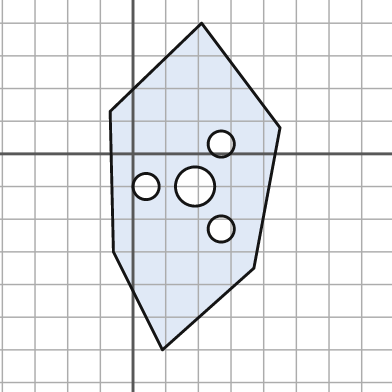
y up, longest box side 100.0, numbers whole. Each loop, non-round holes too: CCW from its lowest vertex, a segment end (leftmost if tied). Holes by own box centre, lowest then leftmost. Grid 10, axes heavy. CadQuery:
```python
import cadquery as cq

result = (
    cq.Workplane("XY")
    .moveTo(9.0, -60.0)
    .lineTo(37.0, -35.0)
    .lineTo(45.0, 8.0)
    .lineTo(21.0, 40.0)
    .lineTo(-7.0, 13.0)
    .lineTo(-6.0, -30.0)
    .close()
    .moveTo(27.0, -23.0)
    .circle(4.0)
    .moveTo(4.0, -10.0)
    .circle(4.0)
    .moveTo(19.0, -10.0)
    .circle(6.0)
    .moveTo(27.0, 3.0)
    .circle(4.0)
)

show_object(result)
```